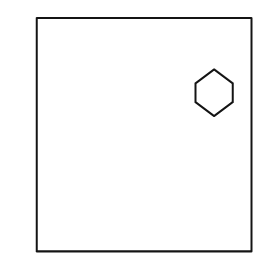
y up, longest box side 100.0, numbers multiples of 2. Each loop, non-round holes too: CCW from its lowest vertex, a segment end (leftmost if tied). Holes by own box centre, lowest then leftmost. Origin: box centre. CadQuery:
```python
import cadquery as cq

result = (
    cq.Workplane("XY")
    .moveTo(-46.0, -50.0)
    .lineTo(46.0, -50.0)
    .lineTo(46.0, 50.0)
    .lineTo(-46.0, 50.0)
    .close()
    .moveTo(30.0, 8.0)
    .lineTo(38.0, 14.0)
    .lineTo(38.0, 22.0)
    .lineTo(30.0, 28.0)
    .lineTo(22.0, 22.0)
    .lineTo(22.0, 14.0)
    .close()
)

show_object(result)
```